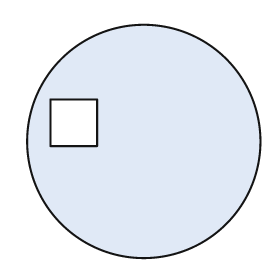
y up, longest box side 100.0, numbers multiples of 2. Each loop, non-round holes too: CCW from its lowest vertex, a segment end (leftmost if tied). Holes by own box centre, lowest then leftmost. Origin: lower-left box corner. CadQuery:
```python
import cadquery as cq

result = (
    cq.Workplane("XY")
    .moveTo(50.0, 50.0)
    .circle(50.0)
    .moveTo(10.0, 48.0)
    .lineTo(30.0, 48.0)
    .lineTo(30.0, 68.0)
    .lineTo(10.0, 68.0)
    .close()
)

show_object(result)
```